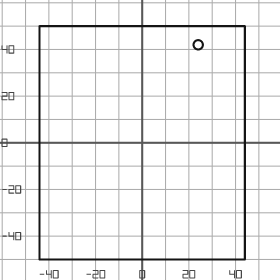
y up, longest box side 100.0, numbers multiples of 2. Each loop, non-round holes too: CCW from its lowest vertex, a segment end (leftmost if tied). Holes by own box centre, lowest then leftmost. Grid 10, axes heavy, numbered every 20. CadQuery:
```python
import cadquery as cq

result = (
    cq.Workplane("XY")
    .moveTo(-44.0, -50.0)
    .lineTo(44.0, -50.0)
    .lineTo(44.0, 50.0)
    .lineTo(-44.0, 50.0)
    .close()
    .moveTo(24.0, 42.0)
    .circle(2.0)
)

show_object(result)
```